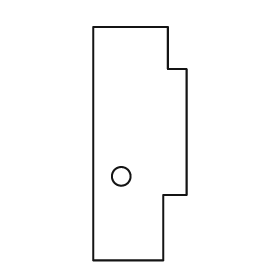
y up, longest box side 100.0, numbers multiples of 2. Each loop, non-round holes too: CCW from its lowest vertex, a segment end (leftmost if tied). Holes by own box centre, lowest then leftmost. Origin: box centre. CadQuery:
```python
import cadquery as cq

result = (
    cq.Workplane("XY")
    .moveTo(-20.0, -50.0)
    .lineTo(10.0, -50.0)
    .lineTo(10.0, -22.0)
    .lineTo(20.0, -22.0)
    .lineTo(20.0, 32.0)
    .lineTo(12.0, 32.0)
    .lineTo(12.0, 50.0)
    .lineTo(-20.0, 50.0)
    .close()
    .moveTo(-8.0, -14.0)
    .circle(4.0)
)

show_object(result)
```